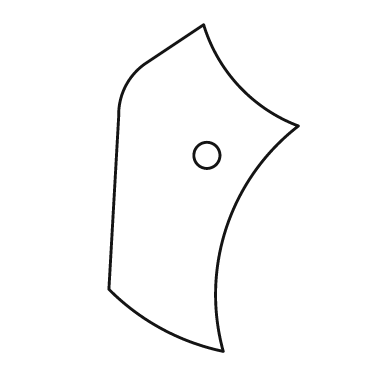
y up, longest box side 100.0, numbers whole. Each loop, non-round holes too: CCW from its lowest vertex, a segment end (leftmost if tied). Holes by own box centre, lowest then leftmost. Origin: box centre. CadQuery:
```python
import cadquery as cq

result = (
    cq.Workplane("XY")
    .moveTo(6.0, -50.0)
    .threePointArc((7.0, -12.0), (29.0, 19.0))
    .threePointArc((11.0, 31.0), (0.0, 50.0))
    .lineTo(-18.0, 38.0)
    .threePointArc((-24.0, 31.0), (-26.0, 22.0))
    .lineTo(-29.0, -31.0)
    .threePointArc((-13.0, -43.0), (6.0, -50.0))
    .close()
    .moveTo(1.0, 10.0)
    .circle(4.0)
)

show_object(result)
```